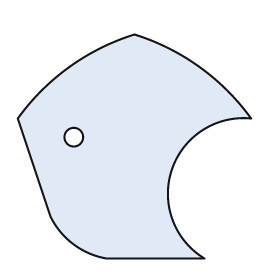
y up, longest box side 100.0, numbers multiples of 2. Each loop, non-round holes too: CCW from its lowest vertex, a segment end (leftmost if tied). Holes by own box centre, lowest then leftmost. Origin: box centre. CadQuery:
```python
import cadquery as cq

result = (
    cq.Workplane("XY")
    .moveTo(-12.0, -48.0)
    .lineTo(30.0, -48.0)
    .threePointArc((16.0, -10.0), (50.0, 12.0))
    .threePointArc((28.0, 34.0), (0.0, 48.0))
    .threePointArc((-28.0, 34.0), (-50.0, 12.0))
    .lineTo(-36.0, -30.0)
    .threePointArc((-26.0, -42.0), (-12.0, -48.0))
    .close()
    .moveTo(-26.0, 4.0)
    .circle(4.0)
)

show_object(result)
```